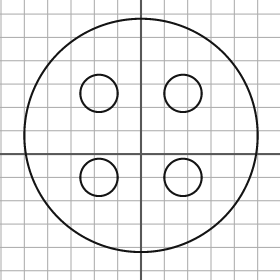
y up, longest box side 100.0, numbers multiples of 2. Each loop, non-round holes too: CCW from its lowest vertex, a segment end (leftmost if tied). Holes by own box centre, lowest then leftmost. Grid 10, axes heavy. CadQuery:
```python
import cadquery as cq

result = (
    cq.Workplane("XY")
    .moveTo(0.0, 8.0)
    .circle(50.0)
    .moveTo(-18.0, -10.0)
    .circle(8.0)
    .moveTo(18.0, -10.0)
    .circle(8.0)
    .moveTo(-18.0, 26.0)
    .circle(8.0)
    .moveTo(18.0, 26.0)
    .circle(8.0)
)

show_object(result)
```